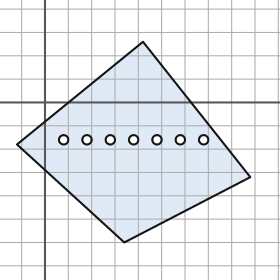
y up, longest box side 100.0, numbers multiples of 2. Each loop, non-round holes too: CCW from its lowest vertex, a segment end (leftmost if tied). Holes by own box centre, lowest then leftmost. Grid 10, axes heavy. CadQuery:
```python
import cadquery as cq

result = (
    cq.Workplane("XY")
    .moveTo(34.0, -60.0)
    .lineTo(88.0, -32.0)
    .lineTo(42.0, 26.0)
    .lineTo(-12.0, -18.0)
    .close()
    .moveTo(8.0, -16.0)
    .circle(2.0)
    .moveTo(18.0, -16.0)
    .circle(2.0)
    .moveTo(28.0, -16.0)
    .circle(2.0)
    .moveTo(38.0, -16.0)
    .circle(2.0)
    .moveTo(48.0, -16.0)
    .circle(2.0)
    .moveTo(58.0, -16.0)
    .circle(2.0)
    .moveTo(68.0, -16.0)
    .circle(2.0)
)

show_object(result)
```